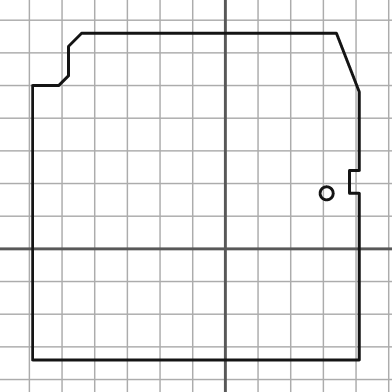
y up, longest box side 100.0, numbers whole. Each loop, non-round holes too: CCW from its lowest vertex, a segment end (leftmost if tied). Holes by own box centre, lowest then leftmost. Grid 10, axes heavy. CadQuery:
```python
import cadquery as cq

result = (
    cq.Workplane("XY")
    .moveTo(-59.0, -34.0)
    .lineTo(41.0, -34.0)
    .lineTo(41.0, 17.0)
    .lineTo(38.0, 17.0)
    .lineTo(38.0, 24.0)
    .lineTo(41.0, 24.0)
    .lineTo(41.0, 48.0)
    .lineTo(34.0, 66.0)
    .lineTo(-44.0, 66.0)
    .lineTo(-48.0, 62.0)
    .lineTo(-48.0, 53.0)
    .lineTo(-51.0, 50.0)
    .lineTo(-59.0, 50.0)
    .close()
    .moveTo(31.0, 17.0)
    .circle(2.0)
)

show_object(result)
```